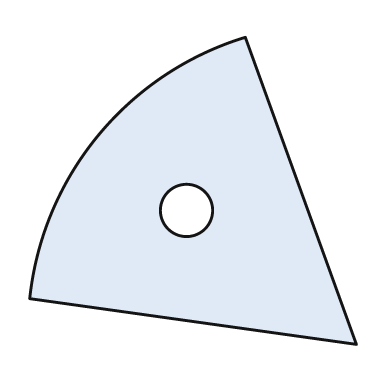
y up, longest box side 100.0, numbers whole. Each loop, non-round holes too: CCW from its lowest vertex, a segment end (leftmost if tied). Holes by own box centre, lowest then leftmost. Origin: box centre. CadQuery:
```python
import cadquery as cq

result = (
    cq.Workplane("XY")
    .moveTo(50.0, -47.0)
    .lineTo(16.0, 47.0)
    .threePointArc((-29.0, 17.0), (-50.0, -33.0))
    .close()
    .moveTo(-2.0, -6.0)
    .circle(8.0)
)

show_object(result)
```